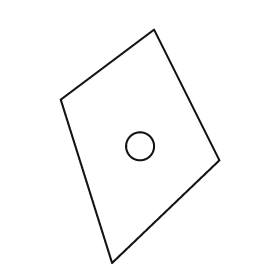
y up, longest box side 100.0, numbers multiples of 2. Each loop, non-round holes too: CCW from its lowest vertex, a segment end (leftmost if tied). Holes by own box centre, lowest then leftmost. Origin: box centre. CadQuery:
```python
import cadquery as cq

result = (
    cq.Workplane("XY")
    .moveTo(-12.0, -50.0)
    .lineTo(34.0, -6.0)
    .lineTo(6.0, 50.0)
    .lineTo(-34.0, 20.0)
    .close()
    .moveTo(0.0, 0.0)
    .circle(6.0)
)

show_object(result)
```